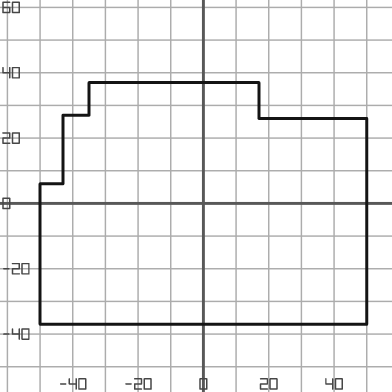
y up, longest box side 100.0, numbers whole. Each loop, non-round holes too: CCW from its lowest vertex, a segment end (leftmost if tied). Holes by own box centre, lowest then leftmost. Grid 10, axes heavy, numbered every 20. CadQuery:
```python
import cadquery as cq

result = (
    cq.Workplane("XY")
    .moveTo(-50.0, -37.0)
    .lineTo(50.0, -37.0)
    .lineTo(50.0, 26.0)
    .lineTo(17.0, 26.0)
    .lineTo(17.0, 37.0)
    .lineTo(-35.0, 37.0)
    .lineTo(-35.0, 27.0)
    .lineTo(-43.0, 27.0)
    .lineTo(-43.0, 6.0)
    .lineTo(-50.0, 6.0)
    .close()
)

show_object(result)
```